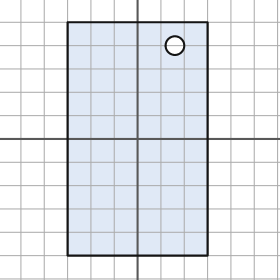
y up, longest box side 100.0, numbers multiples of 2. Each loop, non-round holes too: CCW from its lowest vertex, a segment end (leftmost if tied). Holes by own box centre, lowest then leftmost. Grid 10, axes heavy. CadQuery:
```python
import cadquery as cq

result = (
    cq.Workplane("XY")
    .moveTo(-30.0, -50.0)
    .lineTo(30.0, -50.0)
    .lineTo(30.0, 50.0)
    .lineTo(-30.0, 50.0)
    .close()
    .moveTo(16.0, 40.0)
    .circle(4.0)
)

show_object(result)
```